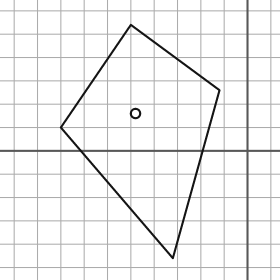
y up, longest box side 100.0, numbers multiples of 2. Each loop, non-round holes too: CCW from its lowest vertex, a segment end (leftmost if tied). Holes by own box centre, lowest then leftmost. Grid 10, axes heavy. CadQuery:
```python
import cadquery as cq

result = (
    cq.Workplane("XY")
    .moveTo(-32.0, -46.0)
    .lineTo(-12.0, 26.0)
    .lineTo(-50.0, 54.0)
    .lineTo(-80.0, 10.0)
    .close()
    .moveTo(-48.0, 16.0)
    .circle(2.0)
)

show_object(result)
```